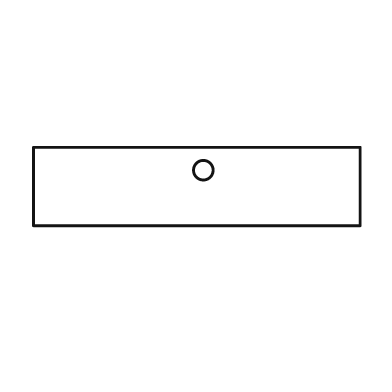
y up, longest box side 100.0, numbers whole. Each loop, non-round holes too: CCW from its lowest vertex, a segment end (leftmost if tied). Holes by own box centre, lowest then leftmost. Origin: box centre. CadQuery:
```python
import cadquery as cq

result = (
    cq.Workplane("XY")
    .moveTo(-50.0, -12.0)
    .lineTo(50.0, -12.0)
    .lineTo(50.0, 12.0)
    .lineTo(-50.0, 12.0)
    .close()
    .moveTo(2.0, 5.0)
    .circle(3.0)
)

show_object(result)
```